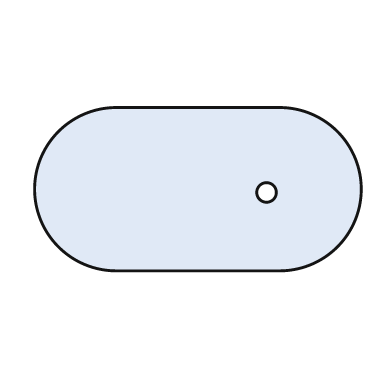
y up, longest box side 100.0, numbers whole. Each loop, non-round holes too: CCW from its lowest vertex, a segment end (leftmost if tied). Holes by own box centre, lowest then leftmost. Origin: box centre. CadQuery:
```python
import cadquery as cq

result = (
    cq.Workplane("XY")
    .moveTo(-25.0, -25.0)
    .lineTo(25.0, -25.0)
    .threePointArc((50.0, 0.0), (25.0, 25.0))
    .lineTo(-25.0, 25.0)
    .threePointArc((-50.0, 0.0), (-25.0, -25.0))
    .close()
    .moveTo(21.0, -1.0)
    .circle(3.0)
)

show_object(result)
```